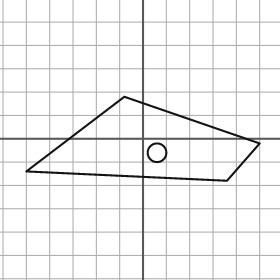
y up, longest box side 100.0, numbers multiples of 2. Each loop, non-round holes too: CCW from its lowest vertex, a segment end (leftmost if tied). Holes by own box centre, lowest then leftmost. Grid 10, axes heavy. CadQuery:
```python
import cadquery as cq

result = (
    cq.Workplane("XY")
    .moveTo(36.0, -18.0)
    .lineTo(50.0, -2.0)
    .lineTo(-8.0, 18.0)
    .lineTo(-50.0, -14.0)
    .close()
    .moveTo(6.0, -6.0)
    .circle(4.0)
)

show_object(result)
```